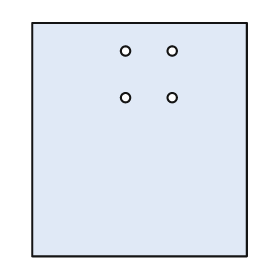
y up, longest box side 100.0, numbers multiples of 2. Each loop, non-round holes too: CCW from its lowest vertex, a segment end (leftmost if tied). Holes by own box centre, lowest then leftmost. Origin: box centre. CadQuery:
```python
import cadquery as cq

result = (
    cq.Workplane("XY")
    .moveTo(-46.0, -50.0)
    .lineTo(46.0, -50.0)
    .lineTo(46.0, 50.0)
    .lineTo(-46.0, 50.0)
    .close()
    .moveTo(-6.0, 18.0)
    .circle(2.0)
    .moveTo(14.0, 18.0)
    .circle(2.0)
    .moveTo(-6.0, 38.0)
    .circle(2.0)
    .moveTo(14.0, 38.0)
    .circle(2.0)
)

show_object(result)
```